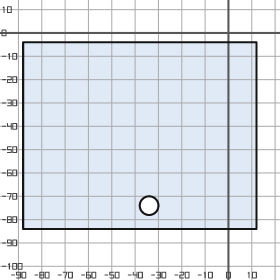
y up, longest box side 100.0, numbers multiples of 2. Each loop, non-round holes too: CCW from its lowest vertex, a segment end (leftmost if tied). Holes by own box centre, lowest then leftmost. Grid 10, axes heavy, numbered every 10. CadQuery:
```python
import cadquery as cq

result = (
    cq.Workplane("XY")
    .moveTo(-88.0, -84.0)
    .lineTo(12.0, -84.0)
    .lineTo(12.0, -4.0)
    .lineTo(-88.0, -4.0)
    .close()
    .moveTo(-34.0, -74.0)
    .circle(4.0)
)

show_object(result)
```